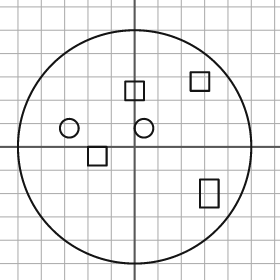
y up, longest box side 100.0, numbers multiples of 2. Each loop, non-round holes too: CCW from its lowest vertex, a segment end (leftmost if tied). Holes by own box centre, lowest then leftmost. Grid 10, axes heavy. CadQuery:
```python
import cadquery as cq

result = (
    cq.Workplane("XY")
    .moveTo(0.0, 0.0)
    .circle(50.0)
    .moveTo(28.0, -26.0)
    .lineTo(36.0, -26.0)
    .lineTo(36.0, -14.0)
    .lineTo(28.0, -14.0)
    .close()
    .moveTo(-20.0, -8.0)
    .lineTo(-12.0, -8.0)
    .lineTo(-12.0, 0.0)
    .lineTo(-20.0, 0.0)
    .close()
    .moveTo(-28.0, 8.0)
    .circle(4.0)
    .moveTo(4.0, 8.0)
    .circle(4.0)
    .moveTo(-4.0, 20.0)
    .lineTo(4.0, 20.0)
    .lineTo(4.0, 28.0)
    .lineTo(-4.0, 28.0)
    .close()
    .moveTo(24.0, 24.0)
    .lineTo(32.0, 24.0)
    .lineTo(32.0, 32.0)
    .lineTo(24.0, 32.0)
    .close()
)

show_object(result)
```